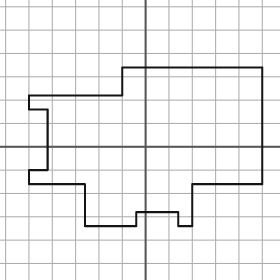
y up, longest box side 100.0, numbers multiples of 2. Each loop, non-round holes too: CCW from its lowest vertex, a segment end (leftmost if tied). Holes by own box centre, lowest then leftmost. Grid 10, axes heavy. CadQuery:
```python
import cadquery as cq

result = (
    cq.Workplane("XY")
    .moveTo(-26.0, -34.0)
    .lineTo(-4.0, -34.0)
    .lineTo(-4.0, -28.0)
    .lineTo(14.0, -28.0)
    .lineTo(14.0, -34.0)
    .lineTo(20.0, -34.0)
    .lineTo(20.0, -16.0)
    .lineTo(50.0, -16.0)
    .lineTo(50.0, 34.0)
    .lineTo(-10.0, 34.0)
    .lineTo(-10.0, 22.0)
    .lineTo(-50.0, 22.0)
    .lineTo(-50.0, 16.0)
    .lineTo(-42.0, 16.0)
    .lineTo(-42.0, -10.0)
    .lineTo(-50.0, -10.0)
    .lineTo(-50.0, -16.0)
    .lineTo(-26.0, -16.0)
    .close()
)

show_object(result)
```